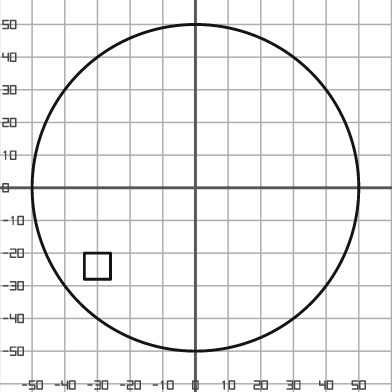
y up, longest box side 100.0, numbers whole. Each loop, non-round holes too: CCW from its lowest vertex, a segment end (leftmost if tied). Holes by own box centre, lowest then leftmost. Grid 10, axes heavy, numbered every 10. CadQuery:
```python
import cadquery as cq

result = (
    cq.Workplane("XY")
    .moveTo(0.0, 0.0)
    .circle(50.0)
    .moveTo(-34.0, -28.0)
    .lineTo(-26.0, -28.0)
    .lineTo(-26.0, -20.0)
    .lineTo(-34.0, -20.0)
    .close()
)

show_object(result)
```